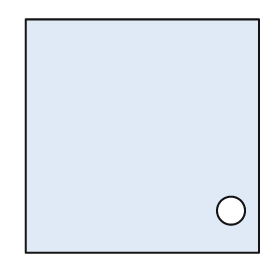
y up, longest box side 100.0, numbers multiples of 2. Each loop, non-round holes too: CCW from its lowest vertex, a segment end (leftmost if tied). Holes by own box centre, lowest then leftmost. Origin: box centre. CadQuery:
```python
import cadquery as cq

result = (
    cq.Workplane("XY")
    .moveTo(-50.0, -50.0)
    .lineTo(50.0, -50.0)
    .lineTo(50.0, 50.0)
    .lineTo(-50.0, 50.0)
    .close()
    .moveTo(38.0, -32.0)
    .circle(6.0)
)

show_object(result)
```